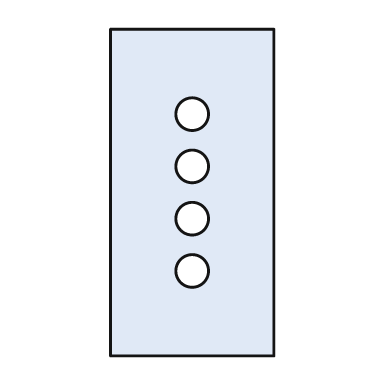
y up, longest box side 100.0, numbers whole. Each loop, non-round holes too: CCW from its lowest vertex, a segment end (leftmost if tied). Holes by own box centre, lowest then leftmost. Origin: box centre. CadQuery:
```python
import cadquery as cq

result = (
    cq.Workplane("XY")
    .moveTo(-25.0, -50.0)
    .lineTo(25.0, -50.0)
    .lineTo(25.0, 50.0)
    .lineTo(-25.0, 50.0)
    .close()
    .moveTo(0.0, -24.0)
    .circle(5.0)
    .moveTo(0.0, -8.0)
    .circle(5.0)
    .moveTo(0.0, 8.0)
    .circle(5.0)
    .moveTo(0.0, 24.0)
    .circle(5.0)
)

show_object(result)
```